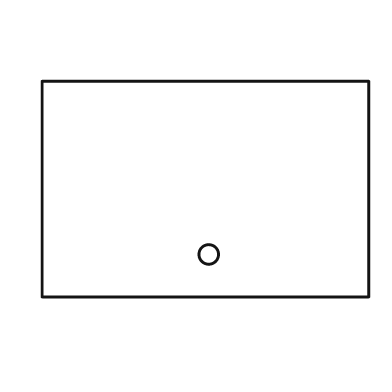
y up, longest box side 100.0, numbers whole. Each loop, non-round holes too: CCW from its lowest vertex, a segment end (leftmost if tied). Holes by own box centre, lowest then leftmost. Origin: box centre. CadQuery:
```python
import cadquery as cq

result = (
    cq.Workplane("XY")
    .moveTo(-50.0, -33.0)
    .lineTo(50.0, -33.0)
    .lineTo(50.0, 33.0)
    .lineTo(-50.0, 33.0)
    .close()
    .moveTo(1.0, -20.0)
    .circle(3.0)
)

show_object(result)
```